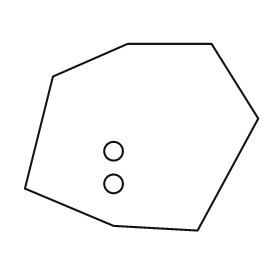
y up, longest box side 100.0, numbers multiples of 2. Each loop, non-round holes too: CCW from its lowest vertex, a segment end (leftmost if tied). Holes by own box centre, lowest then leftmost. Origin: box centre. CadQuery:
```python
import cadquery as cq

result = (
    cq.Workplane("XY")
    .moveTo(24.0, -40.0)
    .lineTo(50.0, 8.0)
    .lineTo(30.0, 40.0)
    .lineTo(-6.0, 40.0)
    .lineTo(-38.0, 26.0)
    .lineTo(-50.0, -22.0)
    .lineTo(-12.0, -38.0)
    .close()
    .moveTo(-12.0, -20.0)
    .circle(4.0)
    .moveTo(-12.0, -6.0)
    .circle(4.0)
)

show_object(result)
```